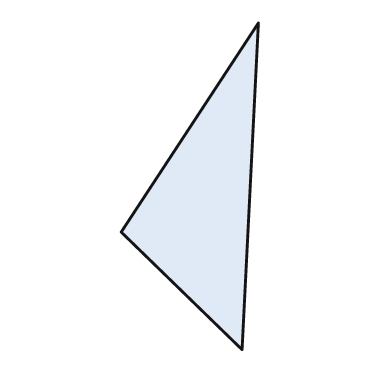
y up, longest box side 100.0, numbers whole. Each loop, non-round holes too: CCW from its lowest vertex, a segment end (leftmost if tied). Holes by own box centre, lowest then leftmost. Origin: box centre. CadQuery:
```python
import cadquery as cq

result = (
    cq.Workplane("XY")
    .moveTo(16.0, -50.0)
    .lineTo(21.0, 50.0)
    .lineTo(-21.0, -14.0)
    .close()
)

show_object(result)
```